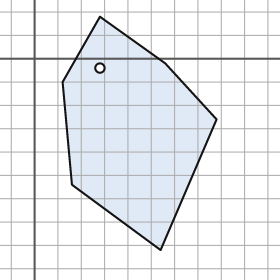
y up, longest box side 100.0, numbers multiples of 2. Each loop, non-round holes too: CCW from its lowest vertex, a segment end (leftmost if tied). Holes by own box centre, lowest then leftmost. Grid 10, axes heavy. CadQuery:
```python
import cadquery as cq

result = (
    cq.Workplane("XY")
    .moveTo(54.0, -82.0)
    .lineTo(78.0, -26.0)
    .lineTo(56.0, -2.0)
    .lineTo(28.0, 18.0)
    .lineTo(12.0, -10.0)
    .lineTo(16.0, -54.0)
    .close()
    .moveTo(28.0, -4.0)
    .circle(2.0)
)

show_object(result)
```